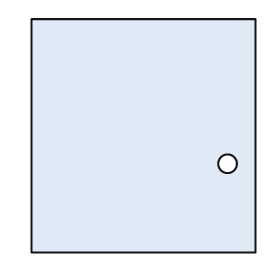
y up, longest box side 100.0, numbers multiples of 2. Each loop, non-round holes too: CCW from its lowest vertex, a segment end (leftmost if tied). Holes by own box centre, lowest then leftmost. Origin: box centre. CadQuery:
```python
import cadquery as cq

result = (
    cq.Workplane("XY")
    .moveTo(-48.0, -50.0)
    .lineTo(48.0, -50.0)
    .lineTo(48.0, 50.0)
    .lineTo(-48.0, 50.0)
    .close()
    .moveTo(36.0, -12.0)
    .circle(4.0)
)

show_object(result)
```